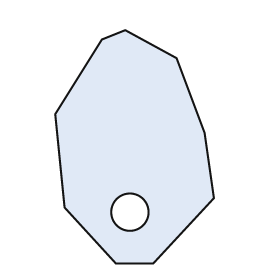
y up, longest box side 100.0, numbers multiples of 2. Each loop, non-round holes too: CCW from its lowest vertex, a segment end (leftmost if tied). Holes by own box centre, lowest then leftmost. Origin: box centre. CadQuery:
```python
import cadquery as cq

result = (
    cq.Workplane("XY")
    .moveTo(-8.0, -50.0)
    .lineTo(8.0, -50.0)
    .lineTo(34.0, -22.0)
    .lineTo(30.0, 6.0)
    .lineTo(18.0, 38.0)
    .lineTo(-4.0, 50.0)
    .lineTo(-14.0, 46.0)
    .lineTo(-34.0, 14.0)
    .lineTo(-30.0, -26.0)
    .close()
    .moveTo(-2.0, -28.0)
    .circle(8.0)
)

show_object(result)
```